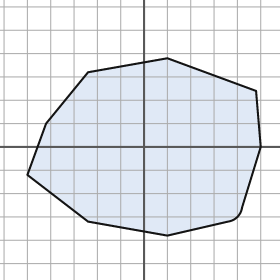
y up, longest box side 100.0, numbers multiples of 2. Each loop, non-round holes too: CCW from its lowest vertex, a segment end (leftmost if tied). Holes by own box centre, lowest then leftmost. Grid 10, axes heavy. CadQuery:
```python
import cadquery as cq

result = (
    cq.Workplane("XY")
    .moveTo(10.0, -38.0)
    .lineTo(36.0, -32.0)
    .threePointArc((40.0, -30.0), (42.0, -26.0))
    .lineTo(50.0, 0.0)
    .lineTo(48.0, 24.0)
    .lineTo(10.0, 38.0)
    .lineTo(-24.0, 32.0)
    .lineTo(-42.0, 10.0)
    .lineTo(-50.0, -12.0)
    .lineTo(-24.0, -32.0)
    .close()
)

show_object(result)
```